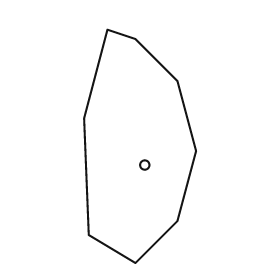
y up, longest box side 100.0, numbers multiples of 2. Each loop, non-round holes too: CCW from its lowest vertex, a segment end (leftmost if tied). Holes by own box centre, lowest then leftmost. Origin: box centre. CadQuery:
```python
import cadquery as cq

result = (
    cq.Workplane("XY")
    .moveTo(-2.0, -50.0)
    .lineTo(16.0, -32.0)
    .lineTo(24.0, -2.0)
    .lineTo(16.0, 28.0)
    .lineTo(-2.0, 46.0)
    .lineTo(-14.0, 50.0)
    .lineTo(-24.0, 12.0)
    .lineTo(-22.0, -38.0)
    .close()
    .moveTo(2.0, -8.0)
    .circle(2.0)
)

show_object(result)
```